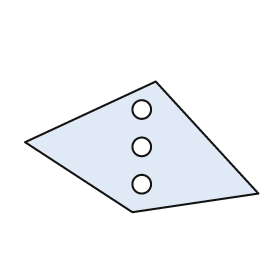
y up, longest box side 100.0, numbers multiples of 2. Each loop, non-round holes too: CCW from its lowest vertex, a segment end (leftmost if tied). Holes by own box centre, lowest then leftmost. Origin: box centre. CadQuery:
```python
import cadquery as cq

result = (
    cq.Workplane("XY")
    .moveTo(-4.0, -28.0)
    .lineTo(50.0, -20.0)
    .lineTo(6.0, 28.0)
    .lineTo(-50.0, 2.0)
    .close()
    .moveTo(0.0, -16.0)
    .circle(4.0)
    .moveTo(0.0, 0.0)
    .circle(4.0)
    .moveTo(0.0, 16.0)
    .circle(4.0)
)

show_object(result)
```